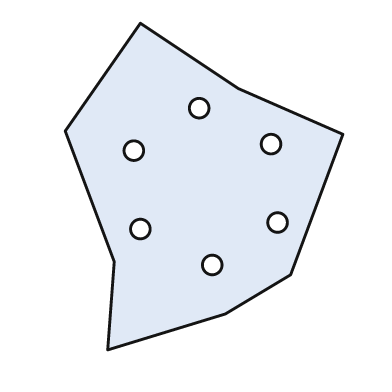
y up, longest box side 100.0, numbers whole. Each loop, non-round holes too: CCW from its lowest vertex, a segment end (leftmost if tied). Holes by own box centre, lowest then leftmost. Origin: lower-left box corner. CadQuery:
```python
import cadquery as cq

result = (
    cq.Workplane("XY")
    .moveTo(13.0, 0.0)
    .lineTo(49.0, 11.0)
    .lineTo(69.0, 23.0)
    .lineTo(85.0, 66.0)
    .lineTo(53.0, 80.0)
    .lineTo(23.0, 100.0)
    .lineTo(0.0, 67.0)
    .lineTo(15.0, 27.0)
    .close()
    .moveTo(45.0, 26.0)
    .circle(3.0)
    .moveTo(23.0, 37.0)
    .circle(3.0)
    .moveTo(65.0, 39.0)
    .circle(3.0)
    .moveTo(21.0, 61.0)
    .circle(3.0)
    .moveTo(63.0, 63.0)
    .circle(3.0)
    .moveTo(41.0, 74.0)
    .circle(3.0)
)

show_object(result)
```